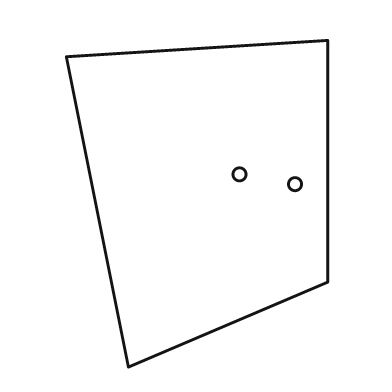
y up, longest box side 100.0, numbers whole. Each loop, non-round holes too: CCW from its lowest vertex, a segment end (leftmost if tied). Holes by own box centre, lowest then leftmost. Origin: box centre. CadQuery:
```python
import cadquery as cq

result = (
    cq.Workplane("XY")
    .moveTo(-21.0, -50.0)
    .lineTo(40.0, -24.0)
    .lineTo(40.0, 50.0)
    .lineTo(-40.0, 45.0)
    .close()
    .moveTo(30.0, 6.0)
    .circle(2.0)
    .moveTo(13.0, 9.0)
    .circle(2.0)
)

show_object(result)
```